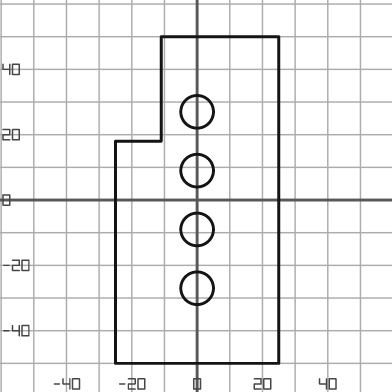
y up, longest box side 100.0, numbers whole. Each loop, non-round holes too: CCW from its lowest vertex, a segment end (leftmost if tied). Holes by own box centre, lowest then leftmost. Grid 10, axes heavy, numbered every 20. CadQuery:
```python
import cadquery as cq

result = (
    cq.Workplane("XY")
    .moveTo(-25.0, -50.0)
    .lineTo(25.0, -50.0)
    .lineTo(25.0, 50.0)
    .lineTo(-11.0, 50.0)
    .lineTo(-11.0, 18.0)
    .lineTo(-25.0, 18.0)
    .close()
    .moveTo(0.0, -27.0)
    .circle(5.0)
    .moveTo(0.0, -9.0)
    .circle(5.0)
    .moveTo(0.0, 9.0)
    .circle(5.0)
    .moveTo(0.0, 27.0)
    .circle(5.0)
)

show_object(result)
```